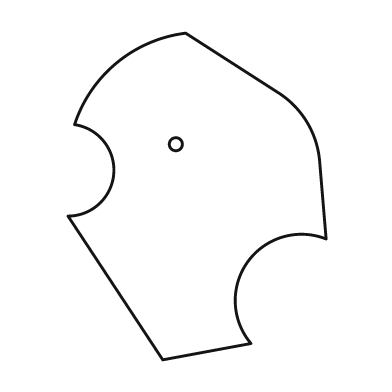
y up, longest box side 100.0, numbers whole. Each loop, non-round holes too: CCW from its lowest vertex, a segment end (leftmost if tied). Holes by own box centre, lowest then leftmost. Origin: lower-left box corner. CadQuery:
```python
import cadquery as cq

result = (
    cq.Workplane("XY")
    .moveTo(29.0, 0.0)
    .lineTo(56.0, 5.0)
    .threePointArc((55.0, 30.0), (79.0, 37.0))
    .lineTo(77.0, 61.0)
    .threePointArc((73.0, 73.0), (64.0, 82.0))
    .lineTo(36.0, 100.0)
    .threePointArc((15.0, 91.0), (2.0, 72.0))
    .threePointArc((14.0, 57.0), (0.0, 44.0))
    .close()
    .moveTo(33.0, 66.0)
    .circle(2.0)
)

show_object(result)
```